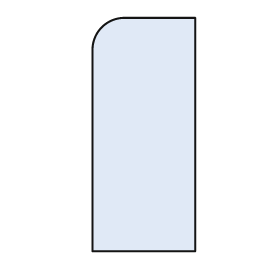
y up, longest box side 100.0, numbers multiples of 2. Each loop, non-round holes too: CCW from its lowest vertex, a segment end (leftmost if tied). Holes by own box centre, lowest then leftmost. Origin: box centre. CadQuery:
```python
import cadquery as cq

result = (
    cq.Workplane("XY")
    .moveTo(-22.0, -50.0)
    .lineTo(22.0, -50.0)
    .lineTo(22.0, 50.0)
    .lineTo(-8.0, 50.0)
    .threePointArc((-18.0, 46.0), (-22.0, 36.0))
    .close()
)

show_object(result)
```